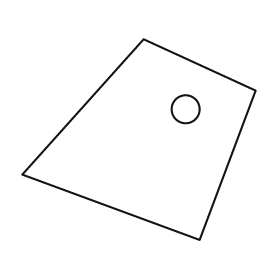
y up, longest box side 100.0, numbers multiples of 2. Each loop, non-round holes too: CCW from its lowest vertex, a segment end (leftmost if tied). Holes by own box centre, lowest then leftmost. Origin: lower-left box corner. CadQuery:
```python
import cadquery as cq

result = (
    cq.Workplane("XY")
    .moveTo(76.0, 0.0)
    .lineTo(100.0, 64.0)
    .lineTo(52.0, 86.0)
    .lineTo(0.0, 28.0)
    .close()
    .moveTo(70.0, 56.0)
    .circle(6.0)
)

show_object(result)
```